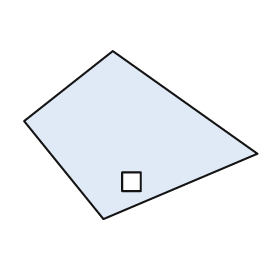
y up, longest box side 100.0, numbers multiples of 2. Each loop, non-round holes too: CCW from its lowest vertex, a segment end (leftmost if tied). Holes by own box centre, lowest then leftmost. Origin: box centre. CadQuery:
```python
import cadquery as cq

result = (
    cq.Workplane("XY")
    .moveTo(-16.0, -36.0)
    .lineTo(50.0, -8.0)
    .lineTo(-12.0, 36.0)
    .lineTo(-50.0, 6.0)
    .close()
    .moveTo(-8.0, -24.0)
    .lineTo(0.0, -24.0)
    .lineTo(0.0, -16.0)
    .lineTo(-8.0, -16.0)
    .close()
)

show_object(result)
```